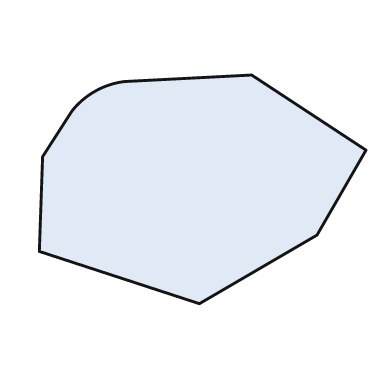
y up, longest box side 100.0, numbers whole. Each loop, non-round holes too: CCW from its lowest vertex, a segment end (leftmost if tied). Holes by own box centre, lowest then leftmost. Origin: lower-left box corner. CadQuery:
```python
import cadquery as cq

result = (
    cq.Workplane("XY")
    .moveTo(49.0, 0.0)
    .lineTo(85.0, 21.0)
    .lineTo(100.0, 47.0)
    .lineTo(65.0, 70.0)
    .lineTo(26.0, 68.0)
    .threePointArc((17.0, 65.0), (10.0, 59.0))
    .lineTo(1.0, 45.0)
    .lineTo(0.0, 16.0)
    .close()
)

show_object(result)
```